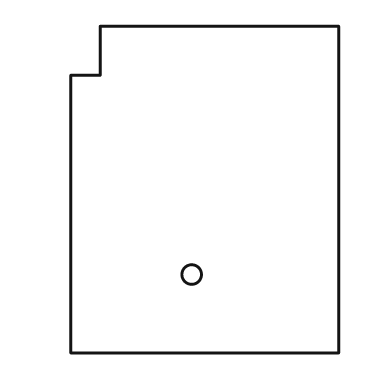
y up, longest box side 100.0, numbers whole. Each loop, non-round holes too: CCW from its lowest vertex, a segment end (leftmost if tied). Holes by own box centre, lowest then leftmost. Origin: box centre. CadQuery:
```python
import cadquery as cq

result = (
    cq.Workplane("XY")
    .moveTo(-41.0, -50.0)
    .lineTo(41.0, -50.0)
    .lineTo(41.0, 50.0)
    .lineTo(-32.0, 50.0)
    .lineTo(-32.0, 35.0)
    .lineTo(-41.0, 35.0)
    .close()
    .moveTo(-4.0, -26.0)
    .circle(3.0)
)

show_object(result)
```